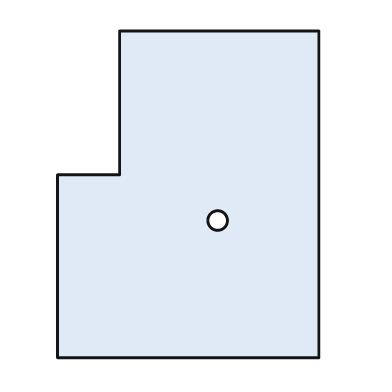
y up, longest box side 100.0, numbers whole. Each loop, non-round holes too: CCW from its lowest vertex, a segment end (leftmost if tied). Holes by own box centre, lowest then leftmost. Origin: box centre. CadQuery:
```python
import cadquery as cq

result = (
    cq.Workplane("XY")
    .moveTo(-40.0, -50.0)
    .lineTo(40.0, -50.0)
    .lineTo(40.0, 50.0)
    .lineTo(-21.0, 50.0)
    .lineTo(-21.0, 6.0)
    .lineTo(-40.0, 6.0)
    .close()
    .moveTo(9.0, -8.0)
    .circle(3.0)
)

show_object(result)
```